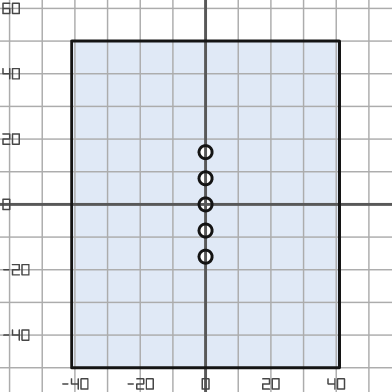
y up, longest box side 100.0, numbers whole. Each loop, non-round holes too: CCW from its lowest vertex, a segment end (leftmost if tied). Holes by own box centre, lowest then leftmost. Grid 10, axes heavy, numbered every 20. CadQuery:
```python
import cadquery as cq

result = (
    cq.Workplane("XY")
    .moveTo(-41.0, -50.0)
    .lineTo(41.0, -50.0)
    .lineTo(41.0, 50.0)
    .lineTo(-41.0, 50.0)
    .close()
    .moveTo(0.0, -16.0)
    .circle(2.0)
    .moveTo(0.0, -8.0)
    .circle(2.0)
    .moveTo(0.0, 0.0)
    .circle(2.0)
    .moveTo(0.0, 8.0)
    .circle(2.0)
    .moveTo(0.0, 16.0)
    .circle(2.0)
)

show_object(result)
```